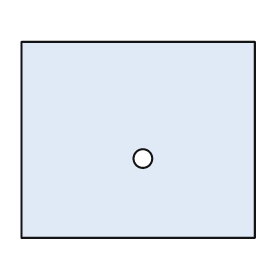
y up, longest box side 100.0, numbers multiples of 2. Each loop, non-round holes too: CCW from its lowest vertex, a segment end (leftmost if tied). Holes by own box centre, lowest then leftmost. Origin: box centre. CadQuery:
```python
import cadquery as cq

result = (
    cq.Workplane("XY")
    .moveTo(-50.0, -42.0)
    .lineTo(50.0, -42.0)
    .lineTo(50.0, 42.0)
    .lineTo(-50.0, 42.0)
    .close()
    .moveTo(2.0, -8.0)
    .circle(4.0)
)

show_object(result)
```